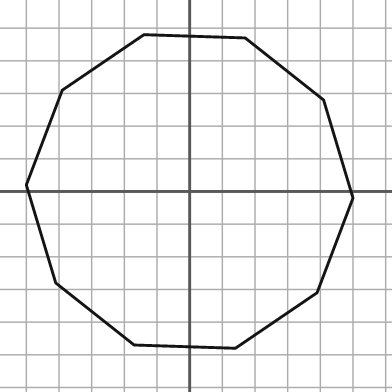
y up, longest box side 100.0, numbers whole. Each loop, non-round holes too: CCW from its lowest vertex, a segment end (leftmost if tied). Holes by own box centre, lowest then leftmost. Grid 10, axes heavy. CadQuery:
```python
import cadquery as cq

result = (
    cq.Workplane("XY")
    .moveTo(14.0, -48.0)
    .lineTo(39.0, -31.0)
    .lineTo(50.0, -2.0)
    .lineTo(41.0, 28.0)
    .lineTo(17.0, 47.0)
    .lineTo(-14.0, 48.0)
    .lineTo(-39.0, 31.0)
    .lineTo(-50.0, 2.0)
    .lineTo(-41.0, -28.0)
    .lineTo(-17.0, -47.0)
    .close()
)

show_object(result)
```